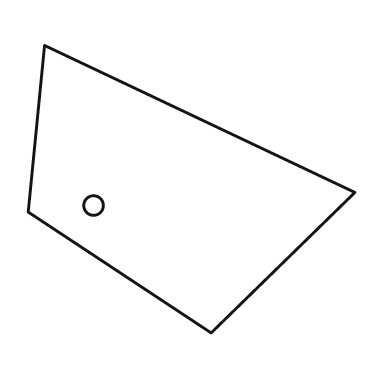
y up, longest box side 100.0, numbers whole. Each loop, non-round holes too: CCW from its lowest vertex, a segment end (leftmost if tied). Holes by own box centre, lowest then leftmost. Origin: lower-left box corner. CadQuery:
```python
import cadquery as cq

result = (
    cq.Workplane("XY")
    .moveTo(56.0, 0.0)
    .lineTo(100.0, 43.0)
    .lineTo(5.0, 88.0)
    .lineTo(0.0, 37.0)
    .close()
    .moveTo(20.0, 39.0)
    .circle(3.0)
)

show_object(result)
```